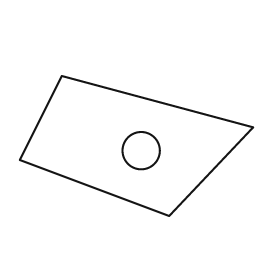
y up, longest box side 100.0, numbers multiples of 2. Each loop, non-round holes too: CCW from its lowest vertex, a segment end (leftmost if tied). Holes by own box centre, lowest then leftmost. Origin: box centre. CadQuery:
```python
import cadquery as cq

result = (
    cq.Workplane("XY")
    .moveTo(14.0, -30.0)
    .lineTo(50.0, 8.0)
    .lineTo(-32.0, 30.0)
    .lineTo(-50.0, -6.0)
    .close()
    .moveTo(2.0, -2.0)
    .circle(8.0)
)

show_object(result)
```